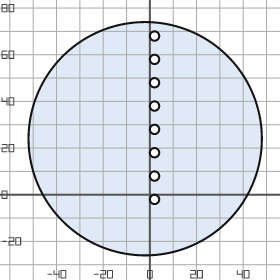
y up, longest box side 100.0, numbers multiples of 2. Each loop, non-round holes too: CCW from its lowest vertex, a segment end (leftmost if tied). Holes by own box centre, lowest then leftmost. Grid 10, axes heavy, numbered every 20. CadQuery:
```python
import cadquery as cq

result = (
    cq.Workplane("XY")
    .moveTo(-2.0, 24.0)
    .circle(50.0)
    .moveTo(2.0, -2.0)
    .circle(2.0)
    .moveTo(2.0, 8.0)
    .circle(2.0)
    .moveTo(2.0, 18.0)
    .circle(2.0)
    .moveTo(2.0, 28.0)
    .circle(2.0)
    .moveTo(2.0, 38.0)
    .circle(2.0)
    .moveTo(2.0, 48.0)
    .circle(2.0)
    .moveTo(2.0, 58.0)
    .circle(2.0)
    .moveTo(2.0, 68.0)
    .circle(2.0)
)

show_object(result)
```